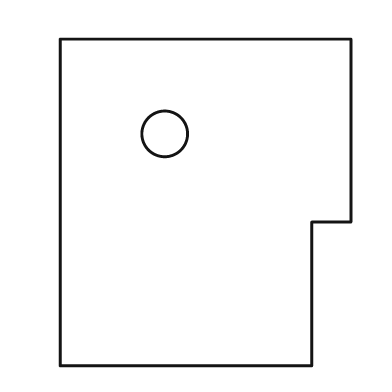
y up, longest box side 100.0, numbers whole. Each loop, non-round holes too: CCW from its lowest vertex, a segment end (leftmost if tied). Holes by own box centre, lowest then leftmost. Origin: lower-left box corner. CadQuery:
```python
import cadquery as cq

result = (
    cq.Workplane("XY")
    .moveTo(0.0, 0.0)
    .lineTo(77.0, 0.0)
    .lineTo(77.0, 44.0)
    .lineTo(89.0, 44.0)
    .lineTo(89.0, 100.0)
    .lineTo(0.0, 100.0)
    .close()
    .moveTo(32.0, 71.0)
    .circle(7.0)
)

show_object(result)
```